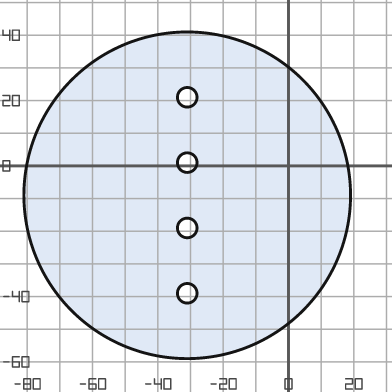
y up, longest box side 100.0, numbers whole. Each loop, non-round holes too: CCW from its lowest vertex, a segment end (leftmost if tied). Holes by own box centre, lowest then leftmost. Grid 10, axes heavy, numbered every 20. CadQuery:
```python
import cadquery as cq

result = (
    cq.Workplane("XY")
    .moveTo(-31.0, -9.0)
    .circle(50.0)
    .moveTo(-31.0, -39.0)
    .circle(3.0)
    .moveTo(-31.0, -19.0)
    .circle(3.0)
    .moveTo(-31.0, 1.0)
    .circle(3.0)
    .moveTo(-31.0, 21.0)
    .circle(3.0)
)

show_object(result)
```